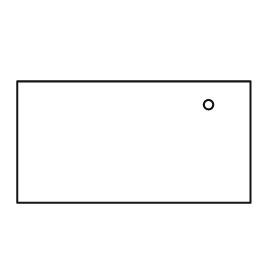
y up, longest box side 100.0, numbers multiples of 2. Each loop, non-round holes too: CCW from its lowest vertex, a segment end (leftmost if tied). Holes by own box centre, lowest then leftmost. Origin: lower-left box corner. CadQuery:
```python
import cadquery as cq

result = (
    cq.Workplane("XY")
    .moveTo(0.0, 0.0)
    .lineTo(100.0, 0.0)
    .lineTo(100.0, 52.0)
    .lineTo(0.0, 52.0)
    .close()
    .moveTo(82.0, 42.0)
    .circle(2.0)
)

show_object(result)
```